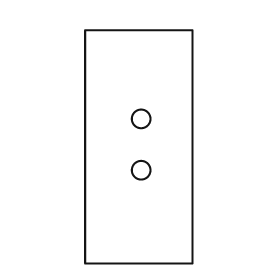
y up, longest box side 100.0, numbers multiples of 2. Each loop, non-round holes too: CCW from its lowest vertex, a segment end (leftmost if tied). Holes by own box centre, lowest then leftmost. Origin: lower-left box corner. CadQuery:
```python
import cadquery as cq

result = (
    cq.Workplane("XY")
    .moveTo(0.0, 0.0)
    .lineTo(46.0, 0.0)
    .lineTo(46.0, 100.0)
    .lineTo(0.0, 100.0)
    .close()
    .moveTo(24.0, 40.0)
    .circle(4.0)
    .moveTo(24.0, 62.0)
    .circle(4.0)
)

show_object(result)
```